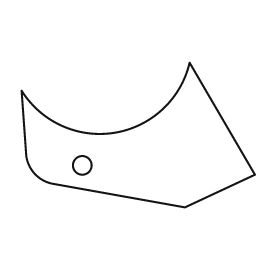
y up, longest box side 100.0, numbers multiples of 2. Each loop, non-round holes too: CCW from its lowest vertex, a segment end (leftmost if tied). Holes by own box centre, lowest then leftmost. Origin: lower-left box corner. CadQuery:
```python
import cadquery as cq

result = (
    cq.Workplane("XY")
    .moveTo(70.0, 0.0)
    .lineTo(100.0, 14.0)
    .lineTo(72.0, 62.0)
    .threePointArc((40.0, 32.0), (0.0, 50.0))
    .lineTo(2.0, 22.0)
    .threePointArc((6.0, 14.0), (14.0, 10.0))
    .close()
    .moveTo(26.0, 18.0)
    .circle(4.0)
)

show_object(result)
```